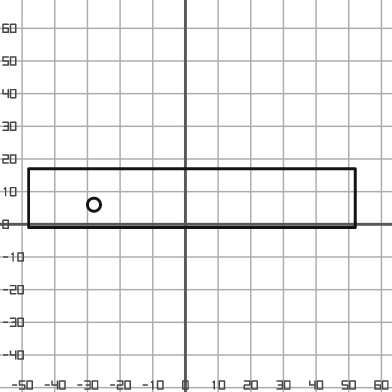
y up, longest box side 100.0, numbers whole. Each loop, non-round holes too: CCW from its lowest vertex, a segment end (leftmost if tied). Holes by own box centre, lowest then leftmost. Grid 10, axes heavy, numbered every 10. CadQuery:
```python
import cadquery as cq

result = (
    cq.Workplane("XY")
    .moveTo(-48.0, -1.0)
    .lineTo(52.0, -1.0)
    .lineTo(52.0, 17.0)
    .lineTo(-48.0, 17.0)
    .close()
    .moveTo(-28.0, 6.0)
    .circle(2.0)
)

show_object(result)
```